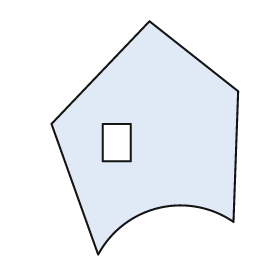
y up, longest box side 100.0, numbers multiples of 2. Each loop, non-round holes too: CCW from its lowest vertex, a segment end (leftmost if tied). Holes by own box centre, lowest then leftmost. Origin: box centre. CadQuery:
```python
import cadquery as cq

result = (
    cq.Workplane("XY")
    .moveTo(-20.0, -50.0)
    .threePointArc((6.0, -30.0), (38.0, -36.0))
    .lineTo(40.0, 20.0)
    .lineTo(2.0, 50.0)
    .lineTo(-40.0, 6.0)
    .close()
    .moveTo(-18.0, -10.0)
    .lineTo(-6.0, -10.0)
    .lineTo(-6.0, 6.0)
    .lineTo(-18.0, 6.0)
    .close()
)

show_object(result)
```